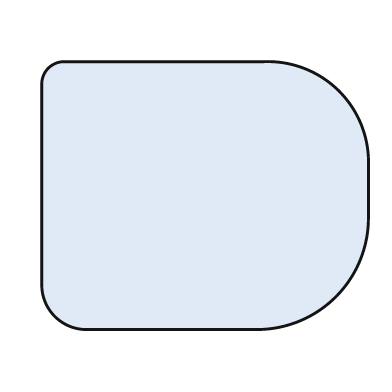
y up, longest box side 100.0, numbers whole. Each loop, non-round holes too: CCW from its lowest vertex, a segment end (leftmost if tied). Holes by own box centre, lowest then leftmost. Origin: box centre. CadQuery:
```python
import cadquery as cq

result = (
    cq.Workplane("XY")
    .moveTo(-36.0, -41.0)
    .lineTo(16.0, -41.0)
    .threePointArc((40.0, -31.0), (50.0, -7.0))
    .lineTo(50.0, 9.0)
    .threePointArc((41.0, 32.0), (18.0, 41.0))
    .lineTo(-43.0, 41.0)
    .threePointArc((-48.0, 39.0), (-50.0, 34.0))
    .lineTo(-50.0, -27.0)
    .threePointArc((-46.0, -37.0), (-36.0, -41.0))
    .close()
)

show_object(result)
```